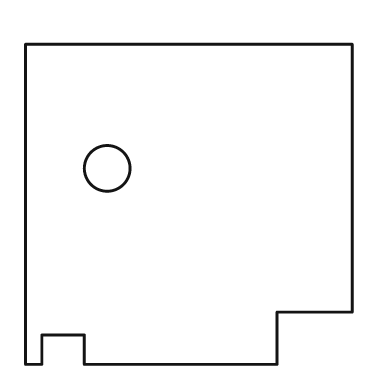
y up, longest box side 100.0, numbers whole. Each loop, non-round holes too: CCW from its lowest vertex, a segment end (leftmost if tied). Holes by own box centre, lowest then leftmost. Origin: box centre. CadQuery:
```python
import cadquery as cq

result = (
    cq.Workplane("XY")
    .moveTo(-50.0, -49.0)
    .lineTo(-45.0, -49.0)
    .lineTo(-45.0, -40.0)
    .lineTo(-32.0, -40.0)
    .lineTo(-32.0, -49.0)
    .lineTo(27.0, -49.0)
    .lineTo(27.0, -33.0)
    .lineTo(50.0, -33.0)
    .lineTo(50.0, 49.0)
    .lineTo(-50.0, 49.0)
    .close()
    .moveTo(-25.0, 11.0)
    .circle(7.0)
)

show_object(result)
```